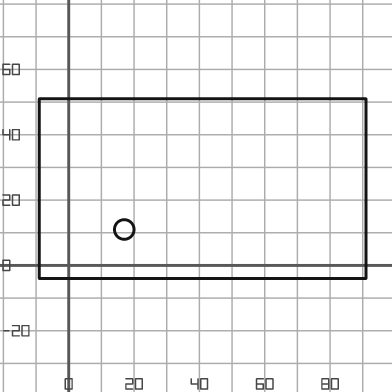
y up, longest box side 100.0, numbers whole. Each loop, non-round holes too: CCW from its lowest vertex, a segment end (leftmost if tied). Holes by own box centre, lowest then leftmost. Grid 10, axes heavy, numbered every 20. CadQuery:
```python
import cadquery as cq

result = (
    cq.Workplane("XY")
    .moveTo(-9.0, -4.0)
    .lineTo(91.0, -4.0)
    .lineTo(91.0, 51.0)
    .lineTo(-9.0, 51.0)
    .close()
    .moveTo(17.0, 11.0)
    .circle(3.0)
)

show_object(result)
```